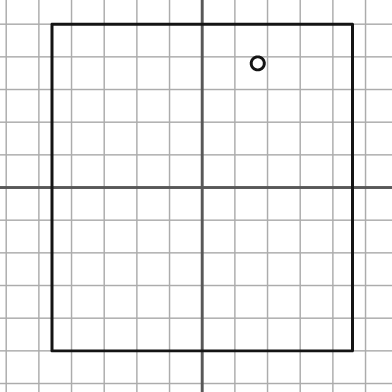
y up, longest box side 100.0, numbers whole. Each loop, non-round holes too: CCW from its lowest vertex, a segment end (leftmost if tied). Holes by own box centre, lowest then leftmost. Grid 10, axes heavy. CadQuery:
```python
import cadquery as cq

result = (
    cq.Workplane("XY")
    .moveTo(-46.0, -50.0)
    .lineTo(46.0, -50.0)
    .lineTo(46.0, 50.0)
    .lineTo(-46.0, 50.0)
    .close()
    .moveTo(17.0, 38.0)
    .circle(2.0)
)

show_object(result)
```